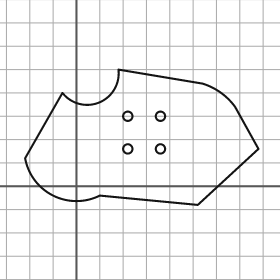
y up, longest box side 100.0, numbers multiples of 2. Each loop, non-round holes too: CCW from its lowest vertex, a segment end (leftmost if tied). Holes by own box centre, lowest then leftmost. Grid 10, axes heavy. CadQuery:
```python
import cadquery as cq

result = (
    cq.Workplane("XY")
    .moveTo(52.0, -8.0)
    .lineTo(78.0, 16.0)
    .lineTo(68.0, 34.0)
    .threePointArc((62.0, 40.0), (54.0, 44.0))
    .lineTo(18.0, 50.0)
    .threePointArc((10.0, 36.0), (-6.0, 40.0))
    .lineTo(-22.0, 12.0)
    .threePointArc((-10.0, -4.0), (10.0, -4.0))
    .close()
    .moveTo(22.0, 16.0)
    .circle(2.0)
    .moveTo(36.0, 16.0)
    .circle(2.0)
    .moveTo(22.0, 30.0)
    .circle(2.0)
    .moveTo(36.0, 30.0)
    .circle(2.0)
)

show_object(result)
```